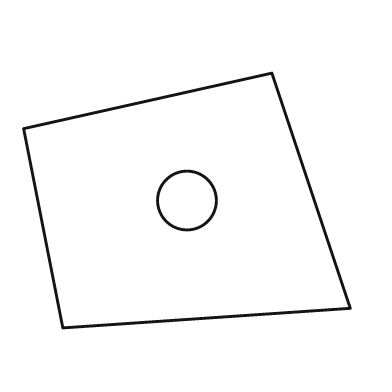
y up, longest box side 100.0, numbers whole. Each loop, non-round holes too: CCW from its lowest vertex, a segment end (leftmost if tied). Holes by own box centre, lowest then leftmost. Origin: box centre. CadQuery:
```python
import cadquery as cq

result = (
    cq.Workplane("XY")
    .moveTo(-38.0, -39.0)
    .lineTo(50.0, -33.0)
    .lineTo(26.0, 39.0)
    .lineTo(-50.0, 22.0)
    .close()
    .moveTo(0.0, 0.0)
    .circle(9.0)
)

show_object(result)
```